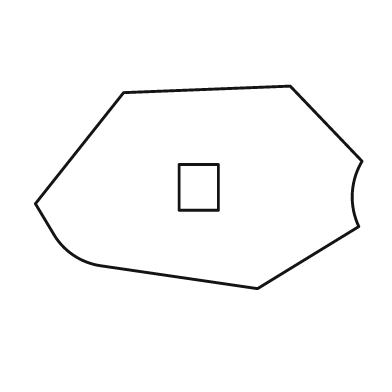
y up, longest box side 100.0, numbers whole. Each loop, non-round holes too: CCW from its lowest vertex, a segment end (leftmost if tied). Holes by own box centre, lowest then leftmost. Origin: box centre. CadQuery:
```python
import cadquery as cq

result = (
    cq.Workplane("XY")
    .moveTo(18.0, -31.0)
    .lineTo(49.0, -12.0)
    .threePointArc((47.0, -2.0), (50.0, 8.0))
    .lineTo(28.0, 31.0)
    .lineTo(-23.0, 29.0)
    .lineTo(-50.0, -5.0)
    .lineTo(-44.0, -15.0)
    .threePointArc((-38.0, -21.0), (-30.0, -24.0))
    .close()
    .moveTo(-6.0, -7.0)
    .lineTo(6.0, -7.0)
    .lineTo(6.0, 7.0)
    .lineTo(-6.0, 7.0)
    .close()
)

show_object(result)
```